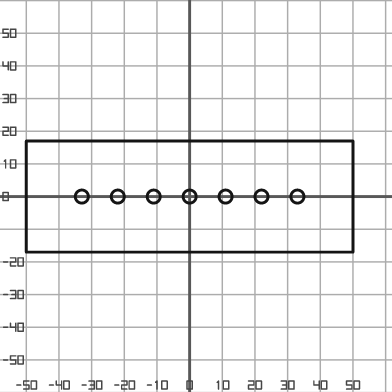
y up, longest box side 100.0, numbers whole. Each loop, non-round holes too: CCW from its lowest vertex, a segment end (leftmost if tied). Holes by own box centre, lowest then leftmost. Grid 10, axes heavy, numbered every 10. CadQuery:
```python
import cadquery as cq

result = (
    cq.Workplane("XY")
    .moveTo(-50.0, -17.0)
    .lineTo(50.0, -17.0)
    .lineTo(50.0, 17.0)
    .lineTo(-50.0, 17.0)
    .close()
    .moveTo(-33.0, 0.0)
    .circle(2.0)
    .moveTo(-22.0, 0.0)
    .circle(2.0)
    .moveTo(-11.0, 0.0)
    .circle(2.0)
    .moveTo(0.0, 0.0)
    .circle(2.0)
    .moveTo(11.0, 0.0)
    .circle(2.0)
    .moveTo(22.0, 0.0)
    .circle(2.0)
    .moveTo(33.0, 0.0)
    .circle(2.0)
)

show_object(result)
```